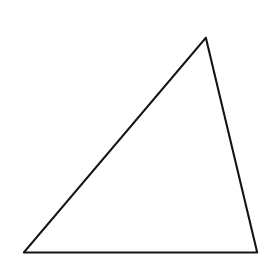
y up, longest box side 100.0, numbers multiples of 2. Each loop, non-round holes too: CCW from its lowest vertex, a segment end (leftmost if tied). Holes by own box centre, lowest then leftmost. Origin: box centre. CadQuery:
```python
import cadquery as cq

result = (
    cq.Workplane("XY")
    .moveTo(-50.0, -46.0)
    .lineTo(50.0, -46.0)
    .lineTo(28.0, 46.0)
    .close()
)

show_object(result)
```